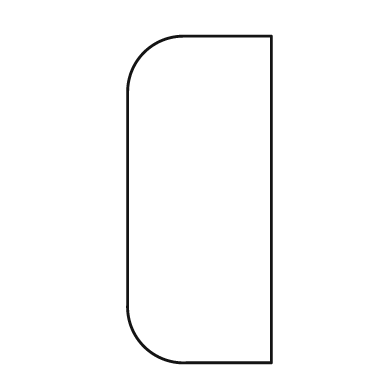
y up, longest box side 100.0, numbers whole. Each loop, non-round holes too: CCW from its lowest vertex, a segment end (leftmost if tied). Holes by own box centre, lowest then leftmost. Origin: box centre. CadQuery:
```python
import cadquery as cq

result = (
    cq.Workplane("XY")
    .moveTo(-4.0, -50.0)
    .lineTo(22.0, -50.0)
    .lineTo(22.0, 50.0)
    .lineTo(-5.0, 50.0)
    .threePointArc((-17.0, 45.0), (-22.0, 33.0))
    .lineTo(-22.0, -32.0)
    .threePointArc((-17.0, -45.0), (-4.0, -50.0))
    .close()
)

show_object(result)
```